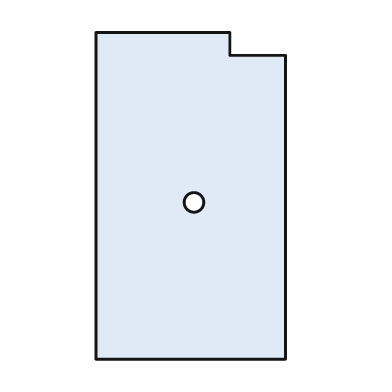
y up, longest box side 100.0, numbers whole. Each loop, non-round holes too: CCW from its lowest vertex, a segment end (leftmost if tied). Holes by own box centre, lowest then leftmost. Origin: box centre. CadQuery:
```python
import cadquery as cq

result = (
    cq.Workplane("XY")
    .moveTo(-29.0, -50.0)
    .lineTo(29.0, -50.0)
    .lineTo(29.0, 43.0)
    .lineTo(12.0, 43.0)
    .lineTo(12.0, 50.0)
    .lineTo(-29.0, 50.0)
    .close()
    .moveTo(1.0, -2.0)
    .circle(3.0)
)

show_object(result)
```